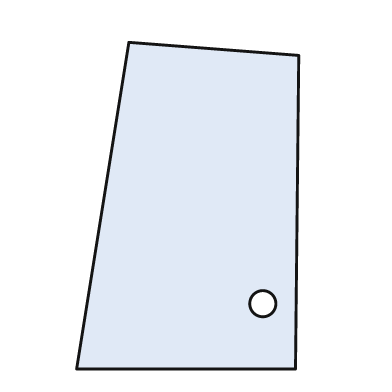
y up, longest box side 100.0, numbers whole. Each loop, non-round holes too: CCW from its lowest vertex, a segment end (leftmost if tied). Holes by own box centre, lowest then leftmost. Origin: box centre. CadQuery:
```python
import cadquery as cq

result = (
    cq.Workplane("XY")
    .moveTo(-34.0, -50.0)
    .lineTo(33.0, -50.0)
    .lineTo(34.0, 46.0)
    .lineTo(-18.0, 50.0)
    .close()
    .moveTo(23.0, -30.0)
    .circle(4.0)
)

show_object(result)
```